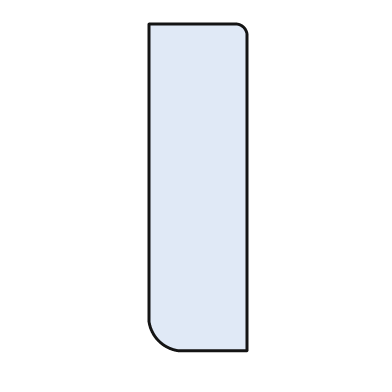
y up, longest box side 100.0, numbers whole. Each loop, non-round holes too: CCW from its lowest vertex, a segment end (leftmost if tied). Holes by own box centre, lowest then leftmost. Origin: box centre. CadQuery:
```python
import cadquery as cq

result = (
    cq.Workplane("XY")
    .moveTo(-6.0, -50.0)
    .lineTo(15.0, -50.0)
    .lineTo(15.0, 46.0)
    .threePointArc((14.0, 49.0), (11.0, 50.0))
    .lineTo(-15.0, 50.0)
    .lineTo(-15.0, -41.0)
    .threePointArc((-12.0, -47.0), (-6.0, -50.0))
    .close()
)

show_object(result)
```